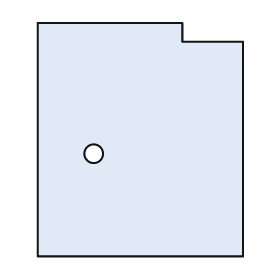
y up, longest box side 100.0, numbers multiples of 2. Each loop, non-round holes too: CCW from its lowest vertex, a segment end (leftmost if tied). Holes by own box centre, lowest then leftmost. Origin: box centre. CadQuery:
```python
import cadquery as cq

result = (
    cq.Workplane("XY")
    .moveTo(-44.0, -50.0)
    .lineTo(44.0, -50.0)
    .lineTo(44.0, 42.0)
    .lineTo(18.0, 42.0)
    .lineTo(18.0, 50.0)
    .lineTo(-44.0, 50.0)
    .close()
    .moveTo(-20.0, -6.0)
    .circle(4.0)
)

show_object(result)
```